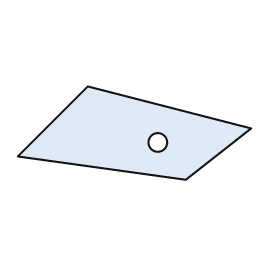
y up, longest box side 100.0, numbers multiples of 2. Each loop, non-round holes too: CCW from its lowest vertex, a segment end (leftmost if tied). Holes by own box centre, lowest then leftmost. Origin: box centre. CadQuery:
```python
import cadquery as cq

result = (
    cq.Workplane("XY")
    .moveTo(22.0, -20.0)
    .lineTo(50.0, 2.0)
    .lineTo(-20.0, 20.0)
    .lineTo(-50.0, -10.0)
    .close()
    .moveTo(10.0, -4.0)
    .circle(4.0)
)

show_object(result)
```